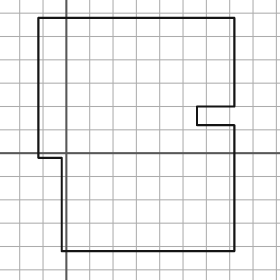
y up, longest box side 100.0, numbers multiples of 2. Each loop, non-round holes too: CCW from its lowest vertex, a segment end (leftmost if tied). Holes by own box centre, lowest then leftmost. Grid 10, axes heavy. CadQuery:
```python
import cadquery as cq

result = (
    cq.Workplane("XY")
    .moveTo(-2.0, -42.0)
    .lineTo(72.0, -42.0)
    .lineTo(72.0, 12.0)
    .lineTo(56.0, 12.0)
    .lineTo(56.0, 20.0)
    .lineTo(72.0, 20.0)
    .lineTo(72.0, 58.0)
    .lineTo(-12.0, 58.0)
    .lineTo(-12.0, -2.0)
    .lineTo(-2.0, -2.0)
    .close()
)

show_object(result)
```